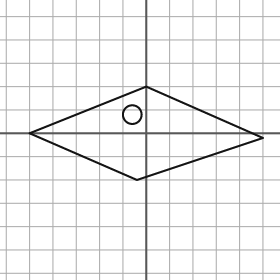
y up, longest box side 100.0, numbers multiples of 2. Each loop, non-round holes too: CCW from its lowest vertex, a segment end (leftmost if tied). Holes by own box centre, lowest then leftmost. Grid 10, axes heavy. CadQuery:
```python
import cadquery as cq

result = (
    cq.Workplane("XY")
    .moveTo(-4.0, -20.0)
    .lineTo(50.0, -2.0)
    .lineTo(0.0, 20.0)
    .lineTo(-50.0, 0.0)
    .close()
    .moveTo(-6.0, 8.0)
    .circle(4.0)
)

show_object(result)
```